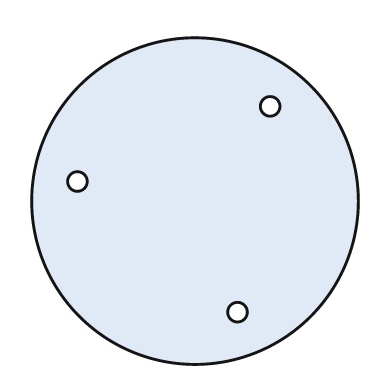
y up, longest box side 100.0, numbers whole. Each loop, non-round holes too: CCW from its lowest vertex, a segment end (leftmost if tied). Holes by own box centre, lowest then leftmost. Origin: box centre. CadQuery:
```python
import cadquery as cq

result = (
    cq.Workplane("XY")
    .moveTo(0.0, 0.0)
    .circle(50.0)
    .moveTo(13.0, -34.0)
    .circle(3.0)
    .moveTo(-36.0, 6.0)
    .circle(3.0)
    .moveTo(23.0, 29.0)
    .circle(3.0)
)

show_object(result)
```